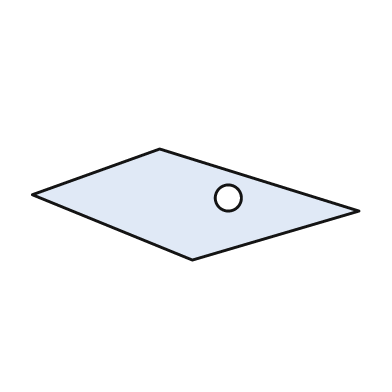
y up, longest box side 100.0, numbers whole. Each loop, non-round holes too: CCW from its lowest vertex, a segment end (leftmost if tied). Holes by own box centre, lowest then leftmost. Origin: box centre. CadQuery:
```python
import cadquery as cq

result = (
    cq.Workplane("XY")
    .moveTo(-1.0, -17.0)
    .lineTo(50.0, -2.0)
    .lineTo(-11.0, 17.0)
    .lineTo(-50.0, 3.0)
    .close()
    .moveTo(10.0, 2.0)
    .circle(4.0)
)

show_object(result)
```